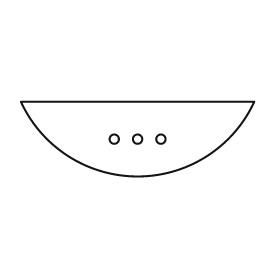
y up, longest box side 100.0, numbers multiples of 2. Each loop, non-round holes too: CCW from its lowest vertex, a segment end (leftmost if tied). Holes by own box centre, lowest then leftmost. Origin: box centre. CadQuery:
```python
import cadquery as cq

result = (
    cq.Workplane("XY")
    .moveTo(-50.0, 16.0)
    .threePointArc((0.0, -16.0), (50.0, 16.0))
    .close()
    .moveTo(-10.0, 0.0)
    .circle(2.0)
    .moveTo(0.0, 0.0)
    .circle(2.0)
    .moveTo(10.0, 0.0)
    .circle(2.0)
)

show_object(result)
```